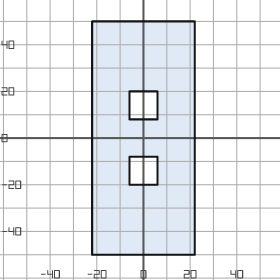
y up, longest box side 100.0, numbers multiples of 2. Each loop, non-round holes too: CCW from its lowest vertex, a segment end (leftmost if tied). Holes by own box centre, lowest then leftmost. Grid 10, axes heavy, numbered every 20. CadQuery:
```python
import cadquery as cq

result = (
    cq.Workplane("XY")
    .moveTo(-22.0, -50.0)
    .lineTo(22.0, -50.0)
    .lineTo(22.0, 50.0)
    .lineTo(-22.0, 50.0)
    .close()
    .moveTo(-6.0, -20.0)
    .lineTo(6.0, -20.0)
    .lineTo(6.0, -8.0)
    .lineTo(-6.0, -8.0)
    .close()
    .moveTo(-6.0, 8.0)
    .lineTo(6.0, 8.0)
    .lineTo(6.0, 20.0)
    .lineTo(-6.0, 20.0)
    .close()
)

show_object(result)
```